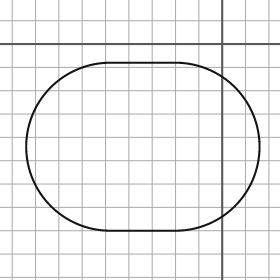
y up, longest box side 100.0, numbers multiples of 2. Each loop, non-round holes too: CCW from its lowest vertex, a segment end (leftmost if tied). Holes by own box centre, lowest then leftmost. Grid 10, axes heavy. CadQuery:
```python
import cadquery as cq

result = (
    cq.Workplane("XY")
    .moveTo(-48.0, -80.0)
    .lineTo(-20.0, -80.0)
    .threePointArc((16.0, -44.0), (-20.0, -8.0))
    .lineTo(-48.0, -8.0)
    .threePointArc((-84.0, -44.0), (-48.0, -80.0))
    .close()
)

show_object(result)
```